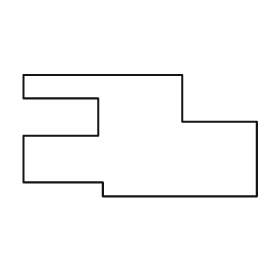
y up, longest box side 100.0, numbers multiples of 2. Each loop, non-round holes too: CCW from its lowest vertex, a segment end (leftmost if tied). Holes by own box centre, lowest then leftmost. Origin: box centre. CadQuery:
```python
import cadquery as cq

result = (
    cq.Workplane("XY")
    .moveTo(-16.0, -26.0)
    .lineTo(50.0, -26.0)
    .lineTo(50.0, 6.0)
    .lineTo(18.0, 6.0)
    .lineTo(18.0, 26.0)
    .lineTo(-50.0, 26.0)
    .lineTo(-50.0, 16.0)
    .lineTo(-18.0, 16.0)
    .lineTo(-18.0, 0.0)
    .lineTo(-50.0, 0.0)
    .lineTo(-50.0, -20.0)
    .lineTo(-16.0, -20.0)
    .close()
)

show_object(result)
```